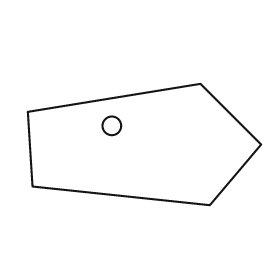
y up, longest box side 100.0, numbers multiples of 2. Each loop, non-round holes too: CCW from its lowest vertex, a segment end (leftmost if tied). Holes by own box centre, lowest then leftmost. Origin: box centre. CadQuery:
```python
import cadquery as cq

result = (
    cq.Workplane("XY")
    .moveTo(28.0, -26.0)
    .lineTo(50.0, 0.0)
    .lineTo(24.0, 26.0)
    .lineTo(-50.0, 14.0)
    .lineTo(-48.0, -18.0)
    .close()
    .moveTo(-14.0, 8.0)
    .circle(4.0)
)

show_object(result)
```